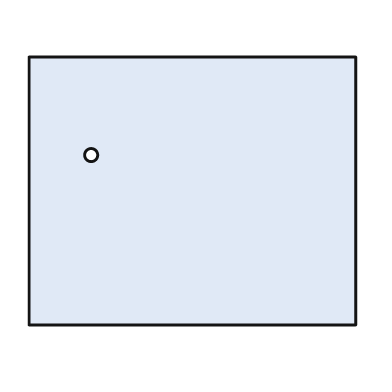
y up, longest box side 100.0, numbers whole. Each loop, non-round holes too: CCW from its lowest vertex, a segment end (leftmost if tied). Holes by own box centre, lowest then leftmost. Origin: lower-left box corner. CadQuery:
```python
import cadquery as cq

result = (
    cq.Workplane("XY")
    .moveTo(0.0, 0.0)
    .lineTo(100.0, 0.0)
    .lineTo(100.0, 82.0)
    .lineTo(0.0, 82.0)
    .close()
    .moveTo(19.0, 52.0)
    .circle(2.0)
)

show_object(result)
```